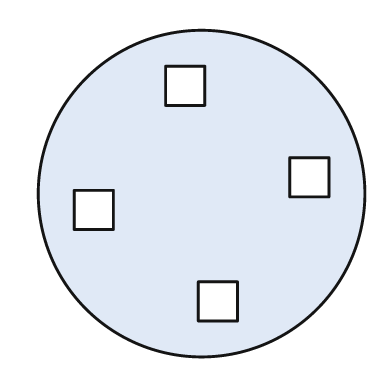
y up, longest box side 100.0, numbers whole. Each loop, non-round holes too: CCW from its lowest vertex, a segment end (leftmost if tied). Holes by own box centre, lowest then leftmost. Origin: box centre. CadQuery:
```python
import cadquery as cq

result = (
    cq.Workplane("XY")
    .moveTo(0.0, 0.0)
    .circle(50.0)
    .moveTo(-1.0, -39.0)
    .lineTo(11.0, -39.0)
    .lineTo(11.0, -27.0)
    .lineTo(-1.0, -27.0)
    .close()
    .moveTo(-39.0, -11.0)
    .lineTo(-27.0, -11.0)
    .lineTo(-27.0, 1.0)
    .lineTo(-39.0, 1.0)
    .close()
    .moveTo(27.0, -1.0)
    .lineTo(39.0, -1.0)
    .lineTo(39.0, 11.0)
    .lineTo(27.0, 11.0)
    .close()
    .moveTo(-11.0, 27.0)
    .lineTo(1.0, 27.0)
    .lineTo(1.0, 39.0)
    .lineTo(-11.0, 39.0)
    .close()
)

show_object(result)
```